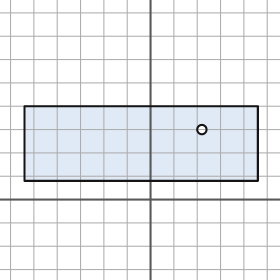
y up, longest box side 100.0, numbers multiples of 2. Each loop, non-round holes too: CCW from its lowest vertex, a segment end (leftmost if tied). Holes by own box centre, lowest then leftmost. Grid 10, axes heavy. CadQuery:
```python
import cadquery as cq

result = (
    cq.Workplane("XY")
    .moveTo(-54.0, 8.0)
    .lineTo(46.0, 8.0)
    .lineTo(46.0, 40.0)
    .lineTo(-54.0, 40.0)
    .close()
    .moveTo(22.0, 30.0)
    .circle(2.0)
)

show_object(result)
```